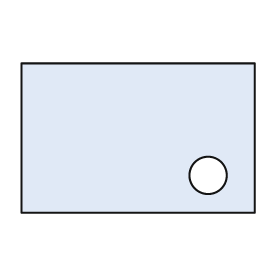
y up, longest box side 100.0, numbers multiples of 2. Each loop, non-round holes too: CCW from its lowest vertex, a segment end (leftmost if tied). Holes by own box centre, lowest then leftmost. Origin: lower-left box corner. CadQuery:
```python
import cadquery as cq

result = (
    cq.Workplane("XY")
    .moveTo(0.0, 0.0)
    .lineTo(100.0, 0.0)
    .lineTo(100.0, 64.0)
    .lineTo(0.0, 64.0)
    .close()
    .moveTo(80.0, 16.0)
    .circle(8.0)
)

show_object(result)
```